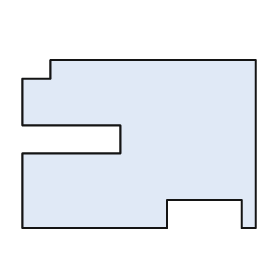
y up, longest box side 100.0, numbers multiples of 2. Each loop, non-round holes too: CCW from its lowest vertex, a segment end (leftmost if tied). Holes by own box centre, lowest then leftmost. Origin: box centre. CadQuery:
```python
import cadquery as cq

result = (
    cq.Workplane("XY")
    .moveTo(-50.0, -36.0)
    .lineTo(12.0, -36.0)
    .lineTo(12.0, -24.0)
    .lineTo(44.0, -24.0)
    .lineTo(44.0, -36.0)
    .lineTo(50.0, -36.0)
    .lineTo(50.0, 36.0)
    .lineTo(-38.0, 36.0)
    .lineTo(-38.0, 28.0)
    .lineTo(-50.0, 28.0)
    .lineTo(-50.0, 8.0)
    .lineTo(-8.0, 8.0)
    .lineTo(-8.0, -4.0)
    .lineTo(-50.0, -4.0)
    .close()
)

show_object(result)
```